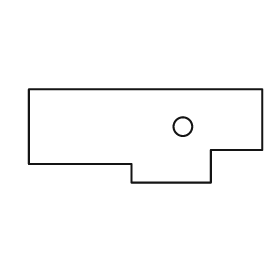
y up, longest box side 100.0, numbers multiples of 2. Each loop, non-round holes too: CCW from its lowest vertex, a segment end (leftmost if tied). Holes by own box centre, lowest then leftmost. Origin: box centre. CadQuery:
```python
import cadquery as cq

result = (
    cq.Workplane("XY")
    .moveTo(-6.0, -20.0)
    .lineTo(28.0, -20.0)
    .lineTo(28.0, -6.0)
    .lineTo(50.0, -6.0)
    .lineTo(50.0, 20.0)
    .lineTo(-50.0, 20.0)
    .lineTo(-50.0, -12.0)
    .lineTo(-6.0, -12.0)
    .close()
    .moveTo(16.0, 4.0)
    .circle(4.0)
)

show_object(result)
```